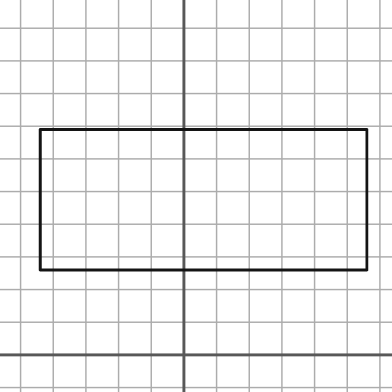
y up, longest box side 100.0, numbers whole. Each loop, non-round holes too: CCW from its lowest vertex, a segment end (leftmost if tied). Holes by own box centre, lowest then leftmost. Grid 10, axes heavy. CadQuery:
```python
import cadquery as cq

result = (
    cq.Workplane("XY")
    .moveTo(-44.0, 26.0)
    .lineTo(56.0, 26.0)
    .lineTo(56.0, 69.0)
    .lineTo(-44.0, 69.0)
    .close()
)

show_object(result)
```